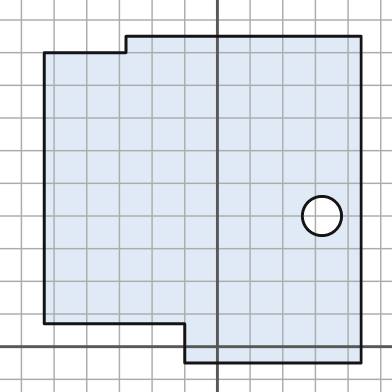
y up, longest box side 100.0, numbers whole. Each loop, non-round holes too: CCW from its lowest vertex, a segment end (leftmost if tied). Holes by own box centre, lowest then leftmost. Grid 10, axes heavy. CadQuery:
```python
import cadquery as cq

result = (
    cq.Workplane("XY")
    .moveTo(-10.0, -5.0)
    .lineTo(44.0, -5.0)
    .lineTo(44.0, 95.0)
    .lineTo(-28.0, 95.0)
    .lineTo(-28.0, 90.0)
    .lineTo(-53.0, 90.0)
    .lineTo(-53.0, 7.0)
    .lineTo(-10.0, 7.0)
    .close()
    .moveTo(32.0, 40.0)
    .circle(6.0)
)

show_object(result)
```